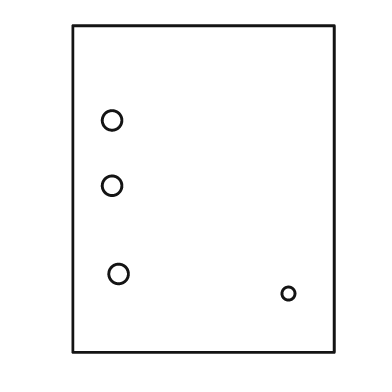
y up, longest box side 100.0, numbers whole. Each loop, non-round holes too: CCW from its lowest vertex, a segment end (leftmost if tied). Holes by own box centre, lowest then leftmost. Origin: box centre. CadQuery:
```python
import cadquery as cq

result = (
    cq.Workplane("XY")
    .moveTo(-40.0, -50.0)
    .lineTo(40.0, -50.0)
    .lineTo(40.0, 50.0)
    .lineTo(-40.0, 50.0)
    .close()
    .moveTo(26.0, -32.0)
    .circle(2.0)
    .moveTo(-26.0, -26.0)
    .circle(3.0)
    .moveTo(-28.0, 1.0)
    .circle(3.0)
    .moveTo(-28.0, 21.0)
    .circle(3.0)
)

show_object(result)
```